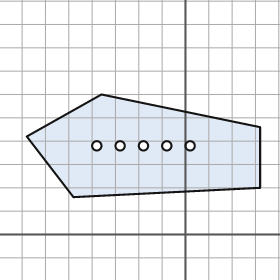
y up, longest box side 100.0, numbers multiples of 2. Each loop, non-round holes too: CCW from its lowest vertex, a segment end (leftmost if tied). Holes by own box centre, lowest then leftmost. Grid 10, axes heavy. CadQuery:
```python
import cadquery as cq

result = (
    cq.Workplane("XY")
    .moveTo(-48.0, 16.0)
    .lineTo(32.0, 20.0)
    .lineTo(32.0, 46.0)
    .lineTo(-36.0, 60.0)
    .lineTo(-68.0, 42.0)
    .close()
    .moveTo(-38.0, 38.0)
    .circle(2.0)
    .moveTo(-28.0, 38.0)
    .circle(2.0)
    .moveTo(-18.0, 38.0)
    .circle(2.0)
    .moveTo(-8.0, 38.0)
    .circle(2.0)
    .moveTo(2.0, 38.0)
    .circle(2.0)
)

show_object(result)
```